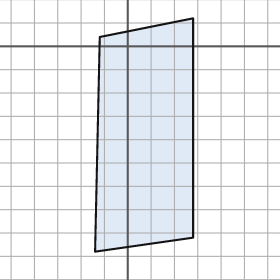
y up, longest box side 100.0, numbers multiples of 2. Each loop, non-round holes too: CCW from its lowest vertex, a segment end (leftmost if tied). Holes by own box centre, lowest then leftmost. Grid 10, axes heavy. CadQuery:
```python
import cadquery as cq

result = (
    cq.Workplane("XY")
    .moveTo(-14.0, -88.0)
    .lineTo(28.0, -82.0)
    .lineTo(28.0, 12.0)
    .lineTo(-12.0, 4.0)
    .close()
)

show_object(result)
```